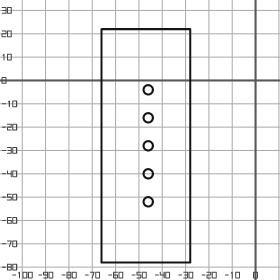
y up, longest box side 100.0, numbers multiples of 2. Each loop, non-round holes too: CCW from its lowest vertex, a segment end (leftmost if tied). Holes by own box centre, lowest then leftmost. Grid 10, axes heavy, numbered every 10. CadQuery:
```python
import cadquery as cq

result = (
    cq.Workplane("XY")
    .moveTo(-66.0, -78.0)
    .lineTo(-28.0, -78.0)
    .lineTo(-28.0, 22.0)
    .lineTo(-66.0, 22.0)
    .close()
    .moveTo(-46.0, -52.0)
    .circle(2.0)
    .moveTo(-46.0, -40.0)
    .circle(2.0)
    .moveTo(-46.0, -28.0)
    .circle(2.0)
    .moveTo(-46.0, -16.0)
    .circle(2.0)
    .moveTo(-46.0, -4.0)
    .circle(2.0)
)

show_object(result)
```